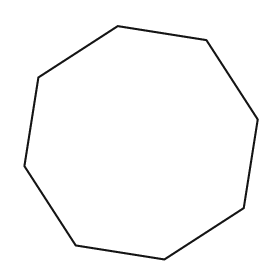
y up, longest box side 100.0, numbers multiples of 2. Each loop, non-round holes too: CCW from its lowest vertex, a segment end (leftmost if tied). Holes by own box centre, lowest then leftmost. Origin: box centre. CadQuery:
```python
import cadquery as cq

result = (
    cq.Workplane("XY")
    .moveTo(10.0, -50.0)
    .lineTo(44.0, -28.0)
    .lineTo(50.0, 10.0)
    .lineTo(28.0, 44.0)
    .lineTo(-10.0, 50.0)
    .lineTo(-44.0, 28.0)
    .lineTo(-50.0, -10.0)
    .lineTo(-28.0, -44.0)
    .close()
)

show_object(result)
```